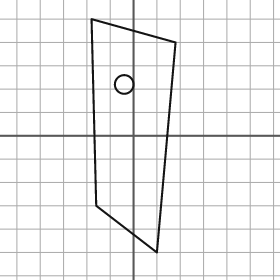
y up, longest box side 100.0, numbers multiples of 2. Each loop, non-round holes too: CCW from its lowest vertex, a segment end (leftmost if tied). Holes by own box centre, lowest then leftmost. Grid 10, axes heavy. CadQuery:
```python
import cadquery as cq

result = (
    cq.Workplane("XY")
    .moveTo(10.0, -50.0)
    .lineTo(18.0, 40.0)
    .lineTo(-18.0, 50.0)
    .lineTo(-16.0, -30.0)
    .close()
    .moveTo(-4.0, 22.0)
    .circle(4.0)
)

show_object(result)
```